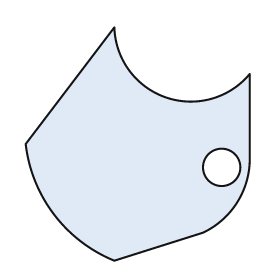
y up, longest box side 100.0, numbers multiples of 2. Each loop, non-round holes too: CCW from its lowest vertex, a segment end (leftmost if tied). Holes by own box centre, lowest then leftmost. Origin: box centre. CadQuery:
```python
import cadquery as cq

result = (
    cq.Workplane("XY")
    .moveTo(-10.0, -50.0)
    .lineTo(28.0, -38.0)
    .threePointArc((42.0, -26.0), (48.0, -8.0))
    .lineTo(48.0, 30.0)
    .threePointArc((12.0, 20.0), (-10.0, 50.0))
    .lineTo(-48.0, 0.0)
    .threePointArc((-36.0, -30.0), (-10.0, -50.0))
    .close()
    .moveTo(36.0, -10.0)
    .circle(8.0)
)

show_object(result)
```